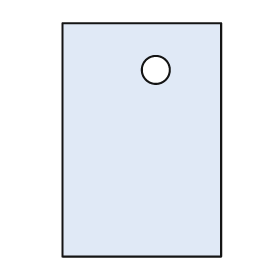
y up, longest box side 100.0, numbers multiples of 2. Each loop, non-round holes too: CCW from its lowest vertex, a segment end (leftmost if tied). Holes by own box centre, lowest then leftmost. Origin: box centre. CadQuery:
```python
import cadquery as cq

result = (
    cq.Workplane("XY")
    .moveTo(-34.0, -50.0)
    .lineTo(34.0, -50.0)
    .lineTo(34.0, 50.0)
    .lineTo(-34.0, 50.0)
    .close()
    .moveTo(6.0, 30.0)
    .circle(6.0)
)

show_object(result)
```